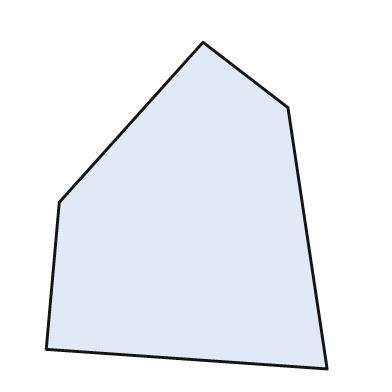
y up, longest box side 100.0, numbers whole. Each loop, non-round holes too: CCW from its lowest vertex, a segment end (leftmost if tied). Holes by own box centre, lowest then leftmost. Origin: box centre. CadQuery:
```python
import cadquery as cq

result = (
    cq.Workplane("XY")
    .moveTo(43.0, -50.0)
    .lineTo(31.0, 30.0)
    .lineTo(5.0, 50.0)
    .lineTo(-39.0, 1.0)
    .lineTo(-43.0, -44.0)
    .close()
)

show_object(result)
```